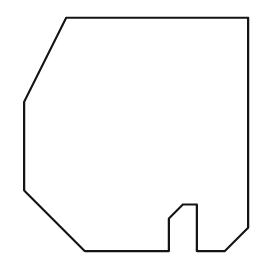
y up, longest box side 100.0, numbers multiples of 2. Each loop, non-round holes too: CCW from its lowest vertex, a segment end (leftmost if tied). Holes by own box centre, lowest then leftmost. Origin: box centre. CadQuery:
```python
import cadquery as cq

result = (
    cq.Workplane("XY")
    .moveTo(-22.0, -50.0)
    .lineTo(14.0, -50.0)
    .lineTo(14.0, -36.0)
    .lineTo(20.0, -30.0)
    .lineTo(26.0, -30.0)
    .lineTo(26.0, -50.0)
    .lineTo(38.0, -50.0)
    .lineTo(48.0, -40.0)
    .lineTo(48.0, 50.0)
    .lineTo(-30.0, 50.0)
    .lineTo(-48.0, 14.0)
    .lineTo(-48.0, -24.0)
    .close()
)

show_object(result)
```